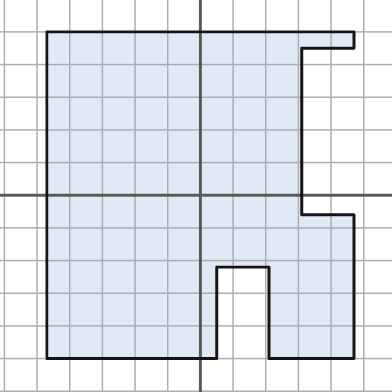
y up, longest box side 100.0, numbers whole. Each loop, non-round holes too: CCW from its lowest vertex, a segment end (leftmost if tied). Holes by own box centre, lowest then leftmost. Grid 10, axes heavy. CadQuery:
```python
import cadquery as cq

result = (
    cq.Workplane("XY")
    .moveTo(-47.0, -50.0)
    .lineTo(5.0, -50.0)
    .lineTo(5.0, -22.0)
    .lineTo(21.0, -22.0)
    .lineTo(21.0, -50.0)
    .lineTo(47.0, -50.0)
    .lineTo(47.0, -6.0)
    .lineTo(31.0, -6.0)
    .lineTo(31.0, 45.0)
    .lineTo(47.0, 45.0)
    .lineTo(47.0, 50.0)
    .lineTo(-47.0, 50.0)
    .close()
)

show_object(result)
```